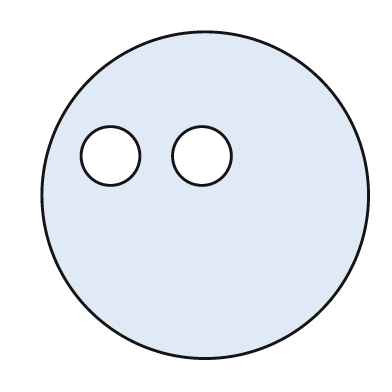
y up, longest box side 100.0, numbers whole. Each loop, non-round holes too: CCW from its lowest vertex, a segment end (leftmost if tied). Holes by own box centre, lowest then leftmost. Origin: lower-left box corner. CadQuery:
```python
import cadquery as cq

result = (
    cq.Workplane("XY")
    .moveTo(50.0, 50.0)
    .circle(50.0)
    .moveTo(21.0, 62.0)
    .circle(9.0)
    .moveTo(49.0, 62.0)
    .circle(9.0)
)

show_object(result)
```